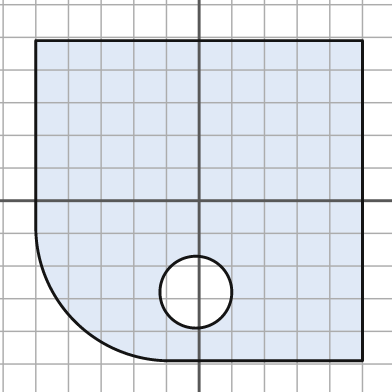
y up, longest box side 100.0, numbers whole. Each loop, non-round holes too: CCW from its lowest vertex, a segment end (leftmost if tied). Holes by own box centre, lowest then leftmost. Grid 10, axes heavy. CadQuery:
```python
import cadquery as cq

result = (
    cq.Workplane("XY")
    .moveTo(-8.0, -49.0)
    .lineTo(50.0, -49.0)
    .lineTo(50.0, 49.0)
    .lineTo(-50.0, 49.0)
    .lineTo(-50.0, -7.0)
    .threePointArc((-38.0, -37.0), (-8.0, -49.0))
    .close()
    .moveTo(-1.0, -28.0)
    .circle(11.0)
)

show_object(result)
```